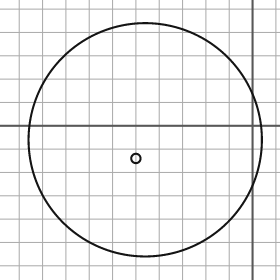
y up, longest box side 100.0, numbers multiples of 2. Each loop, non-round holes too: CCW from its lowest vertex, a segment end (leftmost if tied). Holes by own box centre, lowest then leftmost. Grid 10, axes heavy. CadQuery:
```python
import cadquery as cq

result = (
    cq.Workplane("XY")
    .moveTo(-46.0, -6.0)
    .circle(50.0)
    .moveTo(-50.0, -14.0)
    .circle(2.0)
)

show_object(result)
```